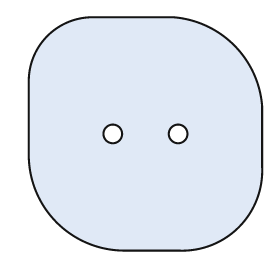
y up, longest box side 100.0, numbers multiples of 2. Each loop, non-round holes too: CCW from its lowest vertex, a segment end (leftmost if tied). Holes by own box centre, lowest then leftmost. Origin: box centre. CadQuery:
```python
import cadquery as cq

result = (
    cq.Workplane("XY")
    .moveTo(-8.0, -50.0)
    .lineTo(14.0, -50.0)
    .threePointArc((40.0, -40.0), (50.0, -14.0))
    .lineTo(50.0, 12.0)
    .threePointArc((38.0, 38.0), (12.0, 50.0))
    .lineTo(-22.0, 50.0)
    .threePointArc((-42.0, 42.0), (-50.0, 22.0))
    .lineTo(-50.0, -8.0)
    .threePointArc((-38.0, -38.0), (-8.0, -50.0))
    .close()
    .moveTo(-14.0, 0.0)
    .circle(4.0)
    .moveTo(14.0, 0.0)
    .circle(4.0)
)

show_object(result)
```